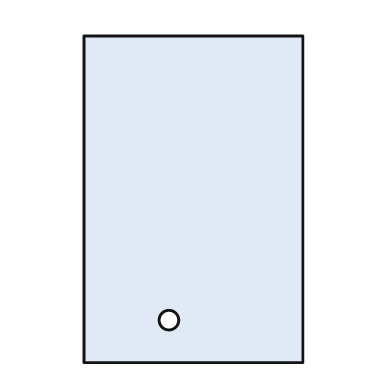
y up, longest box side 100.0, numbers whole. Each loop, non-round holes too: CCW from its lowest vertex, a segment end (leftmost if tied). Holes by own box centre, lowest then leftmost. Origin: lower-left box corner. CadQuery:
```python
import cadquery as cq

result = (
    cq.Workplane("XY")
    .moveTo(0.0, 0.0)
    .lineTo(67.0, 0.0)
    .lineTo(67.0, 100.0)
    .lineTo(0.0, 100.0)
    .close()
    .moveTo(26.0, 13.0)
    .circle(3.0)
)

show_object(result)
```